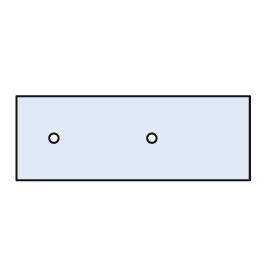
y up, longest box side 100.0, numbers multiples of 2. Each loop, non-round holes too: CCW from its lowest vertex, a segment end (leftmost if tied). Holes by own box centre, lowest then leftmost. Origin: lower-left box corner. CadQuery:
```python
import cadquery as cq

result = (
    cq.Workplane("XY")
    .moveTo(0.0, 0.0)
    .lineTo(100.0, 0.0)
    .lineTo(100.0, 36.0)
    .lineTo(0.0, 36.0)
    .close()
    .moveTo(16.0, 18.0)
    .circle(2.0)
    .moveTo(58.0, 18.0)
    .circle(2.0)
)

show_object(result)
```